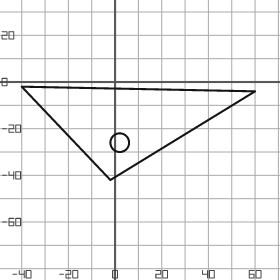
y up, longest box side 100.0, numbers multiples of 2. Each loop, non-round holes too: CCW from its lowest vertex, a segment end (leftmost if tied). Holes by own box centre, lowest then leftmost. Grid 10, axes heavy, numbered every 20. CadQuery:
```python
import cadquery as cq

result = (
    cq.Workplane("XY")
    .moveTo(-2.0, -42.0)
    .lineTo(60.0, -4.0)
    .lineTo(-40.0, -2.0)
    .close()
    .moveTo(2.0, -26.0)
    .circle(4.0)
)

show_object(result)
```